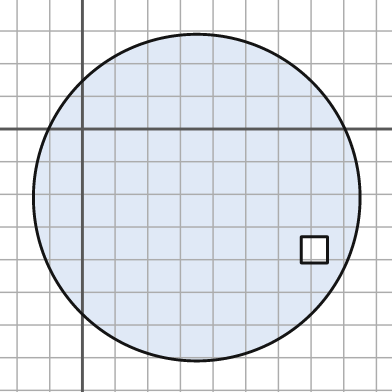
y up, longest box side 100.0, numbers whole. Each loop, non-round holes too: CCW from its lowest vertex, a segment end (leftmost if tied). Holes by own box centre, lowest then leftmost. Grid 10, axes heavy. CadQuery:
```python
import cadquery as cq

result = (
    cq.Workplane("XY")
    .moveTo(35.0, -21.0)
    .circle(50.0)
    .moveTo(67.0, -41.0)
    .lineTo(75.0, -41.0)
    .lineTo(75.0, -33.0)
    .lineTo(67.0, -33.0)
    .close()
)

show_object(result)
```